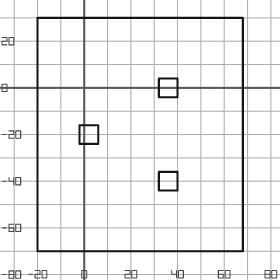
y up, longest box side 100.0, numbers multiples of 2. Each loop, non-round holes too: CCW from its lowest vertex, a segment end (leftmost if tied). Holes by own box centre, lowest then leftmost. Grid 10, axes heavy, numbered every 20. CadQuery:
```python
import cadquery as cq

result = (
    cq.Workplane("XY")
    .moveTo(-20.0, -70.0)
    .lineTo(68.0, -70.0)
    .lineTo(68.0, 30.0)
    .lineTo(-20.0, 30.0)
    .close()
    .moveTo(32.0, -44.0)
    .lineTo(40.0, -44.0)
    .lineTo(40.0, -36.0)
    .lineTo(32.0, -36.0)
    .close()
    .moveTo(-2.0, -24.0)
    .lineTo(6.0, -24.0)
    .lineTo(6.0, -16.0)
    .lineTo(-2.0, -16.0)
    .close()
    .moveTo(32.0, -4.0)
    .lineTo(40.0, -4.0)
    .lineTo(40.0, 4.0)
    .lineTo(32.0, 4.0)
    .close()
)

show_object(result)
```